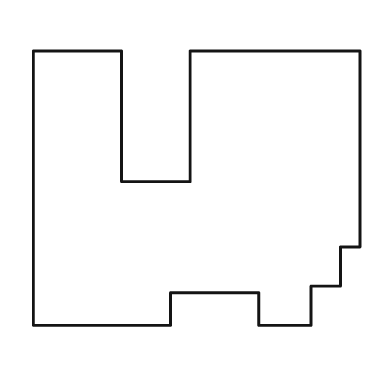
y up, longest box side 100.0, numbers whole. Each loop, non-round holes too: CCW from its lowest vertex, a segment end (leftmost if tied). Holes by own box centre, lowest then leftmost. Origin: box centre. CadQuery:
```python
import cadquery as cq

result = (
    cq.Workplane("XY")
    .moveTo(-50.0, -42.0)
    .lineTo(-8.0, -42.0)
    .lineTo(-8.0, -32.0)
    .lineTo(19.0, -32.0)
    .lineTo(19.0, -42.0)
    .lineTo(35.0, -42.0)
    .lineTo(35.0, -30.0)
    .lineTo(44.0, -30.0)
    .lineTo(44.0, -18.0)
    .lineTo(50.0, -18.0)
    .lineTo(50.0, 42.0)
    .lineTo(-2.0, 42.0)
    .lineTo(-2.0, 2.0)
    .lineTo(-23.0, 2.0)
    .lineTo(-23.0, 42.0)
    .lineTo(-50.0, 42.0)
    .close()
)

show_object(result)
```